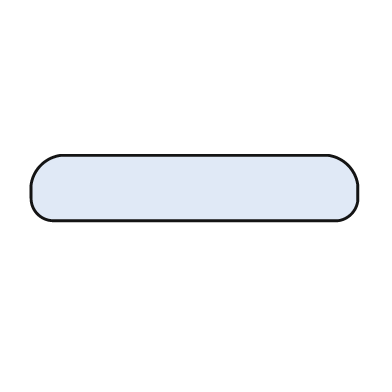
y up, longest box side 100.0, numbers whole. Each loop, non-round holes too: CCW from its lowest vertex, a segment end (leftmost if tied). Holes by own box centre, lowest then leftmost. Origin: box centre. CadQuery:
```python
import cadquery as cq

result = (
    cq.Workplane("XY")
    .moveTo(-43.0, -10.0)
    .lineTo(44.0, -10.0)
    .threePointArc((48.0, -8.0), (50.0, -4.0))
    .lineTo(50.0, 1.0)
    .threePointArc((47.0, 7.0), (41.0, 10.0))
    .lineTo(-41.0, 10.0)
    .threePointArc((-47.0, 7.0), (-50.0, 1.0))
    .lineTo(-50.0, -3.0)
    .threePointArc((-48.0, -8.0), (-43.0, -10.0))
    .close()
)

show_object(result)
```